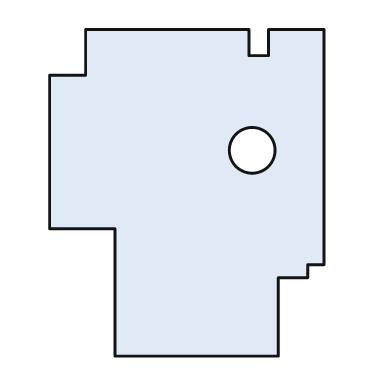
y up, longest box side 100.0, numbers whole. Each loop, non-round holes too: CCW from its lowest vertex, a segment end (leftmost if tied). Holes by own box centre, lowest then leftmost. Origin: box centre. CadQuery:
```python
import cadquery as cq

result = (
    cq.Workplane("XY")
    .moveTo(-22.0, -50.0)
    .lineTo(28.0, -50.0)
    .lineTo(28.0, -26.0)
    .lineTo(37.0, -26.0)
    .lineTo(37.0, -22.0)
    .lineTo(42.0, -22.0)
    .lineTo(42.0, 50.0)
    .lineTo(25.0, 50.0)
    .lineTo(25.0, 42.0)
    .lineTo(19.0, 42.0)
    .lineTo(19.0, 50.0)
    .lineTo(-31.0, 50.0)
    .lineTo(-31.0, 36.0)
    .lineTo(-42.0, 36.0)
    .lineTo(-42.0, -11.0)
    .lineTo(-22.0, -11.0)
    .close()
    .moveTo(20.0, 13.0)
    .circle(7.0)
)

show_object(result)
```